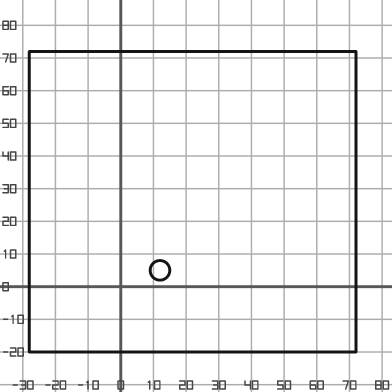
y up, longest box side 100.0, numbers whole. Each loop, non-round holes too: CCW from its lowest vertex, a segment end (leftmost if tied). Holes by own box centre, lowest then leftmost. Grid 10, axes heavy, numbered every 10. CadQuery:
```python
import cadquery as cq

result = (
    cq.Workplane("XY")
    .moveTo(-28.0, -20.0)
    .lineTo(72.0, -20.0)
    .lineTo(72.0, 72.0)
    .lineTo(-28.0, 72.0)
    .close()
    .moveTo(12.0, 5.0)
    .circle(3.0)
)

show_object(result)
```